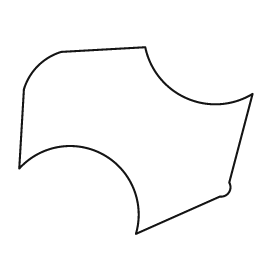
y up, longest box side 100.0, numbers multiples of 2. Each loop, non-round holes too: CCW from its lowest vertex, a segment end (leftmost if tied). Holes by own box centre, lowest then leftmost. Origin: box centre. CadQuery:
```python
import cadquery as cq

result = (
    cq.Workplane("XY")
    .moveTo(0.0, -40.0)
    .lineTo(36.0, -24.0)
    .threePointArc((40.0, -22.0), (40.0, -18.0))
    .lineTo(50.0, 20.0)
    .threePointArc((22.0, 18.0), (4.0, 40.0))
    .lineTo(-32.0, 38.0)
    .threePointArc((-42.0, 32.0), (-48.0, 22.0))
    .lineTo(-50.0, -12.0)
    .threePointArc((-14.0, -6.0), (0.0, -40.0))
    .close()
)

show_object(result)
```